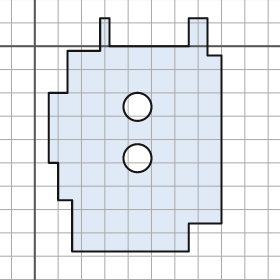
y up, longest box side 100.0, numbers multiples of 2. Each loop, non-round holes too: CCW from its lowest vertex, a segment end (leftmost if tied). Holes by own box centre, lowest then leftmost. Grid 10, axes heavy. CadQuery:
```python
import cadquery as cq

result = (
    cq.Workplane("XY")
    .moveTo(16.0, -88.0)
    .lineTo(66.0, -88.0)
    .lineTo(66.0, -76.0)
    .lineTo(80.0, -76.0)
    .lineTo(80.0, -4.0)
    .lineTo(74.0, -4.0)
    .lineTo(74.0, 12.0)
    .lineTo(66.0, 12.0)
    .lineTo(66.0, 0.0)
    .lineTo(32.0, 0.0)
    .lineTo(32.0, 12.0)
    .lineTo(28.0, 12.0)
    .lineTo(28.0, -2.0)
    .lineTo(14.0, -2.0)
    .lineTo(14.0, -20.0)
    .lineTo(6.0, -20.0)
    .lineTo(6.0, -50.0)
    .lineTo(10.0, -50.0)
    .lineTo(10.0, -66.0)
    .lineTo(16.0, -66.0)
    .close()
    .moveTo(44.0, -48.0)
    .circle(6.0)
    .moveTo(44.0, -26.0)
    .circle(6.0)
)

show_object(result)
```